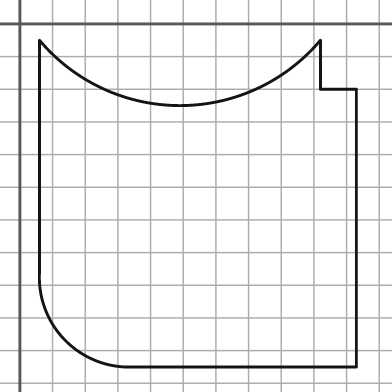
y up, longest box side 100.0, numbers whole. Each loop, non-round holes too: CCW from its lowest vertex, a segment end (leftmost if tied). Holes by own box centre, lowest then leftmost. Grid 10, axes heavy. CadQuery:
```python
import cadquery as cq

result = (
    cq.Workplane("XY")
    .moveTo(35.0, -105.0)
    .lineTo(103.0, -105.0)
    .lineTo(103.0, -20.0)
    .lineTo(92.0, -20.0)
    .lineTo(92.0, -5.0)
    .threePointArc((49.0, -25.0), (6.0, -5.0))
    .lineTo(6.0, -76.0)
    .threePointArc((14.0, -97.0), (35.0, -105.0))
    .close()
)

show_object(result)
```